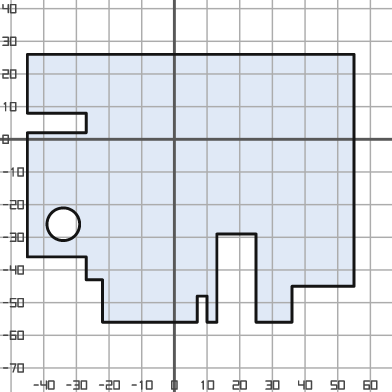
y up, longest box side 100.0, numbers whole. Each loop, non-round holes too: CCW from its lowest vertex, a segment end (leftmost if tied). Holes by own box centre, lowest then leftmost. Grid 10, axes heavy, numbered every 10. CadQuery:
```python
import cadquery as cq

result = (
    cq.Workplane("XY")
    .moveTo(-22.0, -56.0)
    .lineTo(7.0, -56.0)
    .lineTo(7.0, -48.0)
    .lineTo(10.0, -48.0)
    .lineTo(10.0, -56.0)
    .lineTo(13.0, -56.0)
    .lineTo(13.0, -29.0)
    .lineTo(25.0, -29.0)
    .lineTo(25.0, -56.0)
    .lineTo(36.0, -56.0)
    .lineTo(36.0, -45.0)
    .lineTo(55.0, -45.0)
    .lineTo(55.0, 26.0)
    .lineTo(-45.0, 26.0)
    .lineTo(-45.0, 8.0)
    .lineTo(-27.0, 8.0)
    .lineTo(-27.0, 2.0)
    .lineTo(-45.0, 2.0)
    .lineTo(-45.0, -36.0)
    .lineTo(-27.0, -36.0)
    .lineTo(-27.0, -43.0)
    .lineTo(-22.0, -43.0)
    .close()
    .moveTo(-34.0, -26.0)
    .circle(5.0)
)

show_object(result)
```